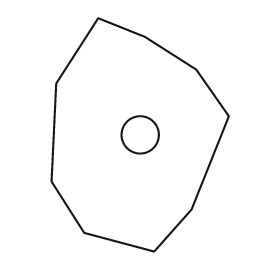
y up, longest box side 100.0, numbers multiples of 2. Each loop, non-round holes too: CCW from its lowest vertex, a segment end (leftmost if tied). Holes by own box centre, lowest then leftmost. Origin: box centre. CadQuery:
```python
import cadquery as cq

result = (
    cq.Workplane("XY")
    .moveTo(6.0, -50.0)
    .lineTo(22.0, -32.0)
    .lineTo(38.0, 8.0)
    .lineTo(24.0, 28.0)
    .lineTo(2.0, 42.0)
    .lineTo(-18.0, 50.0)
    .lineTo(-36.0, 22.0)
    .lineTo(-38.0, -20.0)
    .lineTo(-24.0, -42.0)
    .close()
    .moveTo(0.0, 0.0)
    .circle(8.0)
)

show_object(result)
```